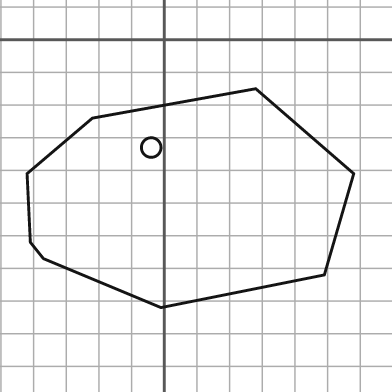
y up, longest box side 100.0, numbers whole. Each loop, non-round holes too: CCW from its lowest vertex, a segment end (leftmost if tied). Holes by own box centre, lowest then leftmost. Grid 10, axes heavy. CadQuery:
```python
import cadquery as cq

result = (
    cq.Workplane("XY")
    .moveTo(-1.0, -82.0)
    .lineTo(49.0, -72.0)
    .lineTo(58.0, -41.0)
    .lineTo(28.0, -15.0)
    .lineTo(-22.0, -24.0)
    .lineTo(-42.0, -41.0)
    .lineTo(-41.0, -62.0)
    .lineTo(-37.0, -67.0)
    .close()
    .moveTo(-4.0, -33.0)
    .circle(3.0)
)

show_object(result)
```